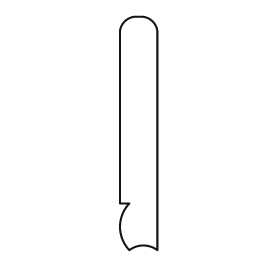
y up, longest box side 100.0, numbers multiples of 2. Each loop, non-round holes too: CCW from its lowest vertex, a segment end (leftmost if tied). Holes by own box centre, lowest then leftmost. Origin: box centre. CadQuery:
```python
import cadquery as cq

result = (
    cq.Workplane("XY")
    .moveTo(-4.0, -50.0)
    .threePointArc((2.0, -48.0), (8.0, -50.0))
    .lineTo(8.0, 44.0)
    .threePointArc((6.0, 48.0), (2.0, 50.0))
    .lineTo(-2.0, 50.0)
    .threePointArc((-6.0, 48.0), (-8.0, 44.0))
    .lineTo(-8.0, -30.0)
    .lineTo(-4.0, -30.0)
    .threePointArc((-8.0, -40.0), (-4.0, -50.0))
    .close()
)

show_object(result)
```